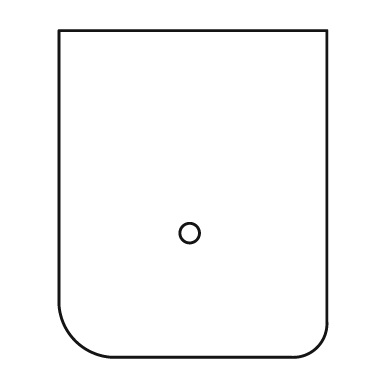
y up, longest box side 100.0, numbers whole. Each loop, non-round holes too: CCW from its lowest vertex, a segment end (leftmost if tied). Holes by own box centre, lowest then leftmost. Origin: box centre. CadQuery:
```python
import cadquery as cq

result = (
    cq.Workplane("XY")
    .moveTo(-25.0, -50.0)
    .lineTo(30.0, -50.0)
    .threePointArc((38.0, -47.0), (41.0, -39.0))
    .lineTo(41.0, 50.0)
    .lineTo(-41.0, 50.0)
    .lineTo(-41.0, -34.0)
    .threePointArc((-36.0, -45.0), (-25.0, -50.0))
    .close()
    .moveTo(-1.0, -12.0)
    .circle(3.0)
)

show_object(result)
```